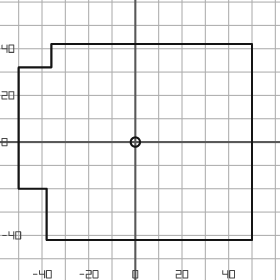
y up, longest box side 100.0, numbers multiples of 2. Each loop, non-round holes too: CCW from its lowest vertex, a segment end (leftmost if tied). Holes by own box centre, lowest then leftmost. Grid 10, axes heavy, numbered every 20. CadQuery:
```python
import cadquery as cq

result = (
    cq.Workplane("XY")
    .moveTo(-38.0, -42.0)
    .lineTo(50.0, -42.0)
    .lineTo(50.0, 42.0)
    .lineTo(-36.0, 42.0)
    .lineTo(-36.0, 32.0)
    .lineTo(-50.0, 32.0)
    .lineTo(-50.0, -20.0)
    .lineTo(-38.0, -20.0)
    .close()
    .moveTo(0.0, 0.0)
    .circle(2.0)
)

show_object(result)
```